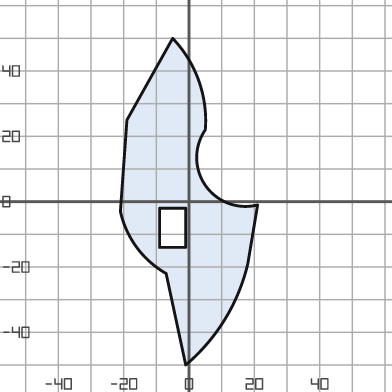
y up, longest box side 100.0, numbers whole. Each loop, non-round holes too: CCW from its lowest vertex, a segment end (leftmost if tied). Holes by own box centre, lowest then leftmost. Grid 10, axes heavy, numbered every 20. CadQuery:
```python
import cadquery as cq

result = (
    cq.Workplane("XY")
    .moveTo(-1.0, -50.0)
    .threePointArc((11.0, -36.0), (18.0, -19.0))
    .lineTo(21.0, -1.0)
    .threePointArc((5.0, 5.0), (5.0, 22.0))
    .threePointArc((3.0, 37.0), (-5.0, 50.0))
    .lineTo(-19.0, 25.0)
    .lineTo(-21.0, -3.0)
    .threePointArc((-16.0, -14.0), (-7.0, -22.0))
    .close()
    .moveTo(-9.0, -14.0)
    .lineTo(-1.0, -14.0)
    .lineTo(-1.0, -2.0)
    .lineTo(-9.0, -2.0)
    .close()
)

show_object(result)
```